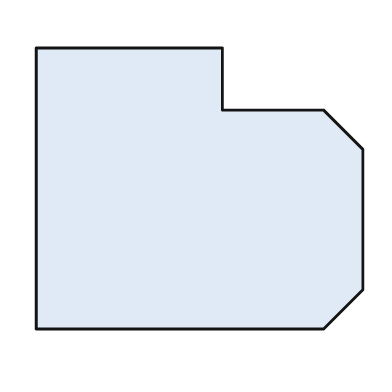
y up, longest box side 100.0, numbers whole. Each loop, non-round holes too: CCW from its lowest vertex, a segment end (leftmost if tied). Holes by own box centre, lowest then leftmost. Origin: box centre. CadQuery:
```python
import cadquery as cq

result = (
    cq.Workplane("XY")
    .moveTo(-50.0, -43.0)
    .lineTo(38.0, -43.0)
    .lineTo(50.0, -31.0)
    .lineTo(50.0, 12.0)
    .lineTo(38.0, 24.0)
    .lineTo(7.0, 24.0)
    .lineTo(7.0, 43.0)
    .lineTo(-50.0, 43.0)
    .close()
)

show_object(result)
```